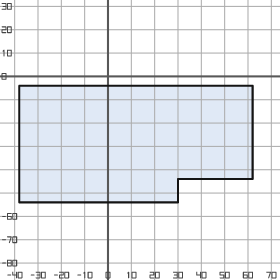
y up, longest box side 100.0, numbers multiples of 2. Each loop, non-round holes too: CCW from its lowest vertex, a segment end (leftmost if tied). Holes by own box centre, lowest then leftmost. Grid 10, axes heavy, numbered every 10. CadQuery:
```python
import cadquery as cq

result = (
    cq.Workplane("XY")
    .moveTo(-38.0, -54.0)
    .lineTo(30.0, -54.0)
    .lineTo(30.0, -44.0)
    .lineTo(62.0, -44.0)
    .lineTo(62.0, -4.0)
    .lineTo(-38.0, -4.0)
    .close()
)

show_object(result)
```